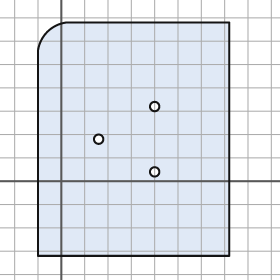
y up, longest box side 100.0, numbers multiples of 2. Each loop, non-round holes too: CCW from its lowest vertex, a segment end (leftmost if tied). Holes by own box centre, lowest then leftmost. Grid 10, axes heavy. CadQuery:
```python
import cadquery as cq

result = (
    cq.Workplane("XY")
    .moveTo(-10.0, -32.0)
    .lineTo(72.0, -32.0)
    .lineTo(72.0, 68.0)
    .lineTo(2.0, 68.0)
    .threePointArc((-6.0, 64.0), (-10.0, 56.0))
    .close()
    .moveTo(40.0, 4.0)
    .circle(2.0)
    .moveTo(16.0, 18.0)
    .circle(2.0)
    .moveTo(40.0, 32.0)
    .circle(2.0)
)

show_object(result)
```